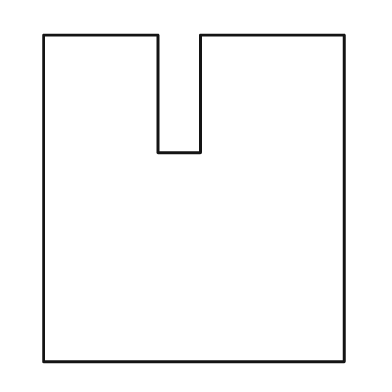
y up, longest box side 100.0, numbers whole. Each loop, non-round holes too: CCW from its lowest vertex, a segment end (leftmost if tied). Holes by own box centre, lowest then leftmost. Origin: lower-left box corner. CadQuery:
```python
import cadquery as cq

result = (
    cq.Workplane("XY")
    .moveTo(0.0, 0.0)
    .lineTo(92.0, 0.0)
    .lineTo(92.0, 100.0)
    .lineTo(48.0, 100.0)
    .lineTo(48.0, 64.0)
    .lineTo(35.0, 64.0)
    .lineTo(35.0, 100.0)
    .lineTo(0.0, 100.0)
    .close()
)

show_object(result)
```